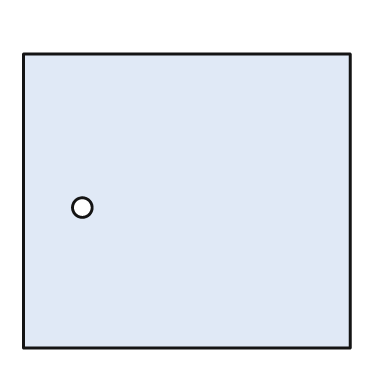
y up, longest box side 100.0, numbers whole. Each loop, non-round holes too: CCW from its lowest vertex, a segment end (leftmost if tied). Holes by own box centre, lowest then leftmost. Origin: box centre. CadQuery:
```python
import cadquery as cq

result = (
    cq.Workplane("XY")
    .moveTo(-50.0, -45.0)
    .lineTo(50.0, -45.0)
    .lineTo(50.0, 45.0)
    .lineTo(-50.0, 45.0)
    .close()
    .moveTo(-32.0, -2.0)
    .circle(3.0)
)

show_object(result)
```